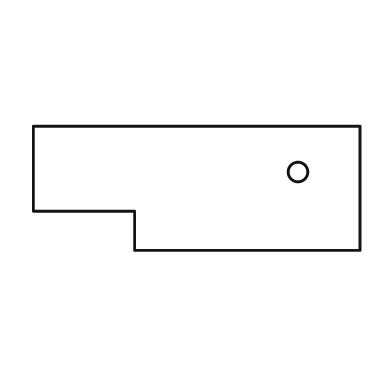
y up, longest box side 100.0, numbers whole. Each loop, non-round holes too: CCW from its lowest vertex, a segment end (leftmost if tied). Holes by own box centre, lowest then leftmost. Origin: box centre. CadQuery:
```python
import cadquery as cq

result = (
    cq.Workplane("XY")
    .moveTo(-19.0, -19.0)
    .lineTo(50.0, -19.0)
    .lineTo(50.0, 19.0)
    .lineTo(-50.0, 19.0)
    .lineTo(-50.0, -7.0)
    .lineTo(-19.0, -7.0)
    .close()
    .moveTo(31.0, 5.0)
    .circle(3.0)
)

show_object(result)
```